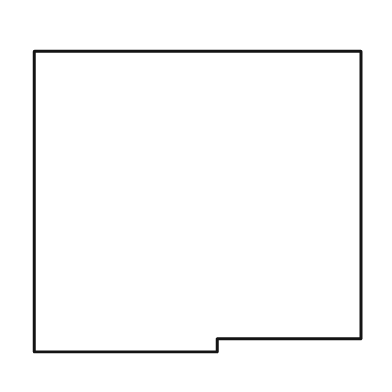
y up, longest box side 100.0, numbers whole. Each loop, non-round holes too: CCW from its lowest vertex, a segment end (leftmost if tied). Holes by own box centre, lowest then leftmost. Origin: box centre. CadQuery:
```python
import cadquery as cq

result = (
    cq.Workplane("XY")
    .moveTo(-50.0, -46.0)
    .lineTo(6.0, -46.0)
    .lineTo(6.0, -42.0)
    .lineTo(50.0, -42.0)
    .lineTo(50.0, 46.0)
    .lineTo(-50.0, 46.0)
    .close()
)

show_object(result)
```